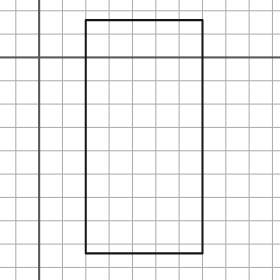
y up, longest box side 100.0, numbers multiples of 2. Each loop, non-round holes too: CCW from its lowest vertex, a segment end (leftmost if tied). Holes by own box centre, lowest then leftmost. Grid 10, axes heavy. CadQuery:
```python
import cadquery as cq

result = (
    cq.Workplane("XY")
    .moveTo(20.0, -84.0)
    .lineTo(70.0, -84.0)
    .lineTo(70.0, 16.0)
    .lineTo(20.0, 16.0)
    .close()
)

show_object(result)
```